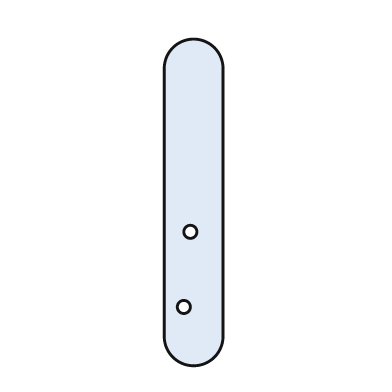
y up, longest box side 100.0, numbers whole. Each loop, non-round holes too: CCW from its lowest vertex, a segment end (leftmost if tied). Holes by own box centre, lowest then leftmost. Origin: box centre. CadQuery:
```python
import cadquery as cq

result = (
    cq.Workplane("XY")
    .moveTo(-9.0, -41.0)
    .threePointArc((0.0, -50.0), (9.0, -41.0))
    .lineTo(9.0, 41.0)
    .threePointArc((0.0, 50.0), (-9.0, 41.0))
    .close()
    .moveTo(-3.0, -32.0)
    .circle(2.0)
    .moveTo(-1.0, -9.0)
    .circle(2.0)
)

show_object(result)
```